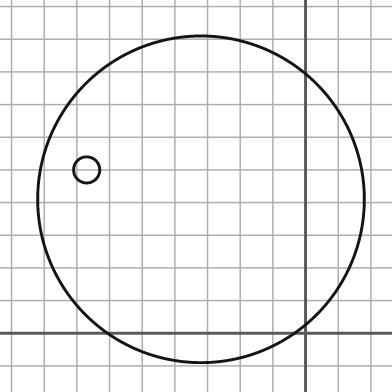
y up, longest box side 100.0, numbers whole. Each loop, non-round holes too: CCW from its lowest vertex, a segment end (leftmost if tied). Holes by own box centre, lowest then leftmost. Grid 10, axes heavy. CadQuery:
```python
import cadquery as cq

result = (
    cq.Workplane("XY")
    .moveTo(-32.0, 41.0)
    .circle(50.0)
    .moveTo(-67.0, 50.0)
    .circle(4.0)
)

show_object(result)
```